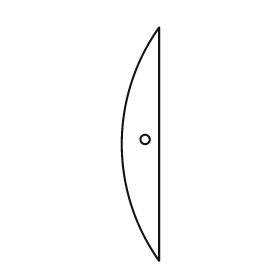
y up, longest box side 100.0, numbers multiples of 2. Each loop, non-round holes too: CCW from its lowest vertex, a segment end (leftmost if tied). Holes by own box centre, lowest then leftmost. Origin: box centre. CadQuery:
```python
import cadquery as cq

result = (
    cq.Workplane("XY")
    .moveTo(8.0, -50.0)
    .lineTo(8.0, 50.0)
    .threePointArc((-8.0, 0.0), (8.0, -50.0))
    .close()
    .moveTo(2.0, 2.0)
    .circle(2.0)
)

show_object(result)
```